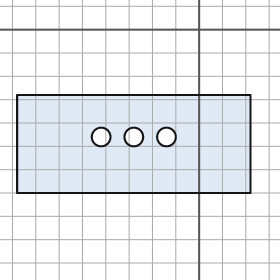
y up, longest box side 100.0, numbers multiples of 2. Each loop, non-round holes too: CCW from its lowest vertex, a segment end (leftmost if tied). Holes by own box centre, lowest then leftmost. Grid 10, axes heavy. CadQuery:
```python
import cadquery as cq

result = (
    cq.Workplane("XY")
    .moveTo(-78.0, -70.0)
    .lineTo(22.0, -70.0)
    .lineTo(22.0, -28.0)
    .lineTo(-78.0, -28.0)
    .close()
    .moveTo(-42.0, -46.0)
    .circle(4.0)
    .moveTo(-28.0, -46.0)
    .circle(4.0)
    .moveTo(-14.0, -46.0)
    .circle(4.0)
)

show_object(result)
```